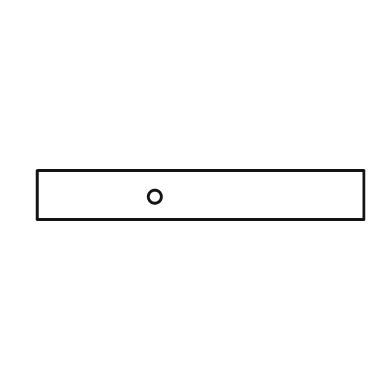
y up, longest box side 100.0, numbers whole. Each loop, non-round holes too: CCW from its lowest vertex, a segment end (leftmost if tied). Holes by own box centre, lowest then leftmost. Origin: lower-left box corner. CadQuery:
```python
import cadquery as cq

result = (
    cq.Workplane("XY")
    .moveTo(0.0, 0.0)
    .lineTo(100.0, 0.0)
    .lineTo(100.0, 15.0)
    .lineTo(0.0, 15.0)
    .close()
    .moveTo(36.0, 7.0)
    .circle(2.0)
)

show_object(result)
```